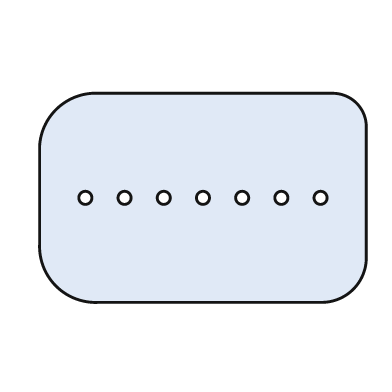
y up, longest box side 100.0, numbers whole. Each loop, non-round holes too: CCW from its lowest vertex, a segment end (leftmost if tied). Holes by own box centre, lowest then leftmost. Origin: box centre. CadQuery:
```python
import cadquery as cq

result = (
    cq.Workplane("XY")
    .moveTo(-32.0, -32.0)
    .lineTo(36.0, -32.0)
    .threePointArc((46.0, -28.0), (50.0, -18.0))
    .lineTo(50.0, 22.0)
    .threePointArc((47.0, 29.0), (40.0, 32.0))
    .lineTo(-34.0, 32.0)
    .threePointArc((-45.0, 27.0), (-50.0, 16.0))
    .lineTo(-50.0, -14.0)
    .threePointArc((-45.0, -27.0), (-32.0, -32.0))
    .close()
    .moveTo(-36.0, 0.0)
    .circle(2.0)
    .moveTo(-24.0, 0.0)
    .circle(2.0)
    .moveTo(-12.0, 0.0)
    .circle(2.0)
    .moveTo(0.0, 0.0)
    .circle(2.0)
    .moveTo(12.0, 0.0)
    .circle(2.0)
    .moveTo(24.0, 0.0)
    .circle(2.0)
    .moveTo(36.0, 0.0)
    .circle(2.0)
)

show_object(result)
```